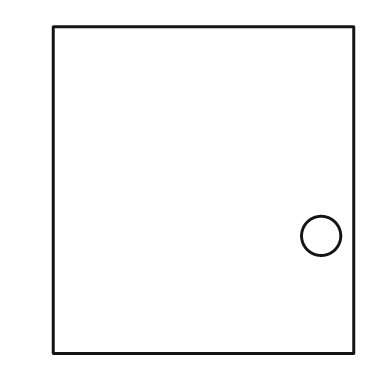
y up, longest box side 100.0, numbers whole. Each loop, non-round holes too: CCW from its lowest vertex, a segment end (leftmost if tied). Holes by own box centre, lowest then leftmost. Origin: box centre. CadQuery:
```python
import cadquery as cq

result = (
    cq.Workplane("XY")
    .moveTo(-46.0, -50.0)
    .lineTo(46.0, -50.0)
    .lineTo(46.0, 50.0)
    .lineTo(-46.0, 50.0)
    .close()
    .moveTo(36.0, -14.0)
    .circle(6.0)
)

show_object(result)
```